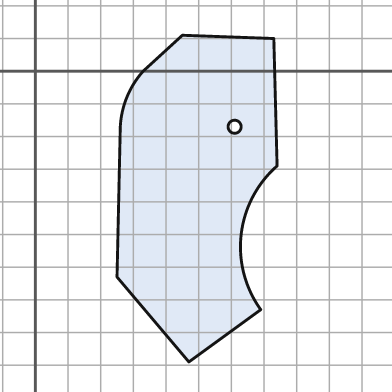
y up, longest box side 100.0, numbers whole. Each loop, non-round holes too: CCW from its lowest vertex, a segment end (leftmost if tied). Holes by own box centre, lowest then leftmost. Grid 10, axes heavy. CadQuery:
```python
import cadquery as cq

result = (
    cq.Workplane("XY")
    .moveTo(47.0, -89.0)
    .lineTo(69.0, -73.0)
    .threePointArc((63.0, -50.0), (74.0, -29.0))
    .lineTo(73.0, 10.0)
    .lineTo(45.0, 11.0)
    .lineTo(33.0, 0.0)
    .threePointArc((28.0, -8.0), (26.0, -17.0))
    .lineTo(25.0, -63.0)
    .close()
    .moveTo(61.0, -17.0)
    .circle(2.0)
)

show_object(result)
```